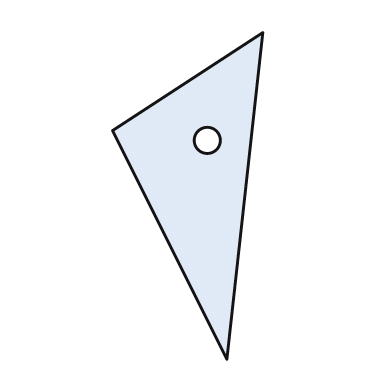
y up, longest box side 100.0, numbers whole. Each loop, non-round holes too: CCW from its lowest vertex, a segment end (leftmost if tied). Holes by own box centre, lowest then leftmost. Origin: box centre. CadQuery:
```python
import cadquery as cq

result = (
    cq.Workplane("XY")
    .moveTo(12.0, -50.0)
    .lineTo(23.0, 50.0)
    .lineTo(-23.0, 20.0)
    .close()
    .moveTo(6.0, 17.0)
    .circle(4.0)
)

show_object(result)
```